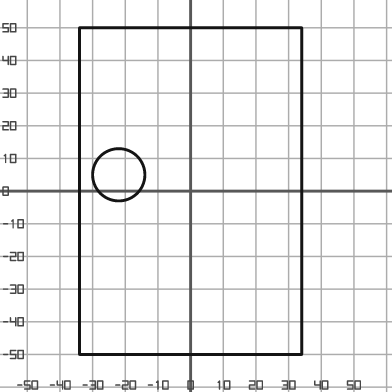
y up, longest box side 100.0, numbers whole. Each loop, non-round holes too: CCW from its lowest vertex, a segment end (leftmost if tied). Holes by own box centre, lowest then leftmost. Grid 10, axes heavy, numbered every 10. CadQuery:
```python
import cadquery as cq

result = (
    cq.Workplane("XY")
    .moveTo(-34.0, -50.0)
    .lineTo(34.0, -50.0)
    .lineTo(34.0, 50.0)
    .lineTo(-34.0, 50.0)
    .close()
    .moveTo(-22.0, 5.0)
    .circle(8.0)
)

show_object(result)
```